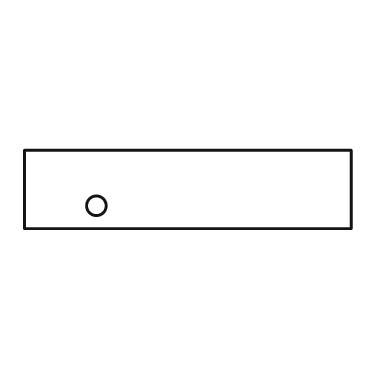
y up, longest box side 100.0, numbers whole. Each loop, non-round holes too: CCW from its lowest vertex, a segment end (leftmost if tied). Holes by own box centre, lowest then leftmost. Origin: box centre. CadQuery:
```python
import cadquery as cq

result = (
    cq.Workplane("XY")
    .moveTo(-50.0, -12.0)
    .lineTo(50.0, -12.0)
    .lineTo(50.0, 12.0)
    .lineTo(-50.0, 12.0)
    .close()
    .moveTo(-28.0, -5.0)
    .circle(3.0)
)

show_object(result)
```